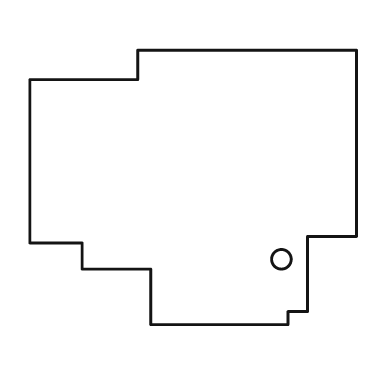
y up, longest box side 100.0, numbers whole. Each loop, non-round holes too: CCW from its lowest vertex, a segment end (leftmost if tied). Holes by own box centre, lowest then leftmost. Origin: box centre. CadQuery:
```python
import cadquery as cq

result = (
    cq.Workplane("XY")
    .moveTo(-13.0, -42.0)
    .lineTo(29.0, -42.0)
    .lineTo(29.0, -38.0)
    .lineTo(35.0, -38.0)
    .lineTo(35.0, -15.0)
    .lineTo(50.0, -15.0)
    .lineTo(50.0, 42.0)
    .lineTo(-17.0, 42.0)
    .lineTo(-17.0, 33.0)
    .lineTo(-50.0, 33.0)
    .lineTo(-50.0, -17.0)
    .lineTo(-34.0, -17.0)
    .lineTo(-34.0, -25.0)
    .lineTo(-13.0, -25.0)
    .close()
    .moveTo(27.0, -22.0)
    .circle(3.0)
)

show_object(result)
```